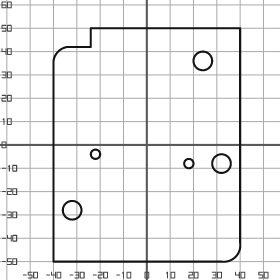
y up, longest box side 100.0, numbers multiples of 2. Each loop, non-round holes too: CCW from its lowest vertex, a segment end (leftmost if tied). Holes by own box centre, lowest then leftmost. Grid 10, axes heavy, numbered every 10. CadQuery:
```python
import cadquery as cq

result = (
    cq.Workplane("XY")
    .moveTo(-40.0, -50.0)
    .lineTo(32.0, -50.0)
    .threePointArc((38.0, -48.0), (40.0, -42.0))
    .lineTo(40.0, 50.0)
    .lineTo(-24.0, 50.0)
    .lineTo(-24.0, 42.0)
    .lineTo(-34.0, 42.0)
    .threePointArc((-38.0, 40.0), (-40.0, 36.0))
    .close()
    .moveTo(-32.0, -28.0)
    .circle(4.0)
    .moveTo(18.0, -8.0)
    .circle(2.0)
    .moveTo(32.0, -8.0)
    .circle(4.0)
    .moveTo(-22.0, -4.0)
    .circle(2.0)
    .moveTo(24.0, 36.0)
    .circle(4.0)
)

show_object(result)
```